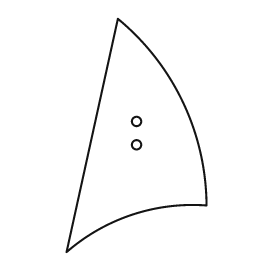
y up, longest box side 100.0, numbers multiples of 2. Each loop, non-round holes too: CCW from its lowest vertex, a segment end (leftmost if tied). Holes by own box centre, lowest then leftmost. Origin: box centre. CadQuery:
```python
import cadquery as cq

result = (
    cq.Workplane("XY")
    .moveTo(-30.0, -50.0)
    .threePointArc((-2.0, -34.0), (30.0, -30.0))
    .threePointArc((20.0, 14.0), (-8.0, 50.0))
    .close()
    .moveTo(0.0, -4.0)
    .circle(2.0)
    .moveTo(0.0, 6.0)
    .circle(2.0)
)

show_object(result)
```